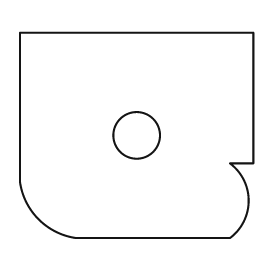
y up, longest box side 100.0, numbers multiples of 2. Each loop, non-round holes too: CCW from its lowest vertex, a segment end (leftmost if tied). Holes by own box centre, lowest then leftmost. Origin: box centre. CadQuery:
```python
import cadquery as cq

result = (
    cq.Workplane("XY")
    .moveTo(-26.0, -44.0)
    .lineTo(40.0, -44.0)
    .threePointArc((48.0, -28.0), (40.0, -12.0))
    .lineTo(50.0, -12.0)
    .lineTo(50.0, 44.0)
    .lineTo(-50.0, 44.0)
    .lineTo(-50.0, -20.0)
    .threePointArc((-42.0, -36.0), (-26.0, -44.0))
    .close()
    .moveTo(0.0, 0.0)
    .circle(10.0)
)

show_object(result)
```